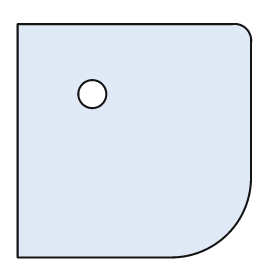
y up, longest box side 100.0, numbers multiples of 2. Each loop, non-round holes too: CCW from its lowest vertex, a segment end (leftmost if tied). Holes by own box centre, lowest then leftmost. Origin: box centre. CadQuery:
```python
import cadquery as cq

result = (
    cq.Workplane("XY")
    .moveTo(-50.0, -50.0)
    .lineTo(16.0, -50.0)
    .threePointArc((40.0, -40.0), (50.0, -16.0))
    .lineTo(50.0, 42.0)
    .threePointArc((48.0, 48.0), (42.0, 50.0))
    .lineTo(-50.0, 50.0)
    .close()
    .moveTo(-18.0, 20.0)
    .circle(6.0)
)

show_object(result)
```